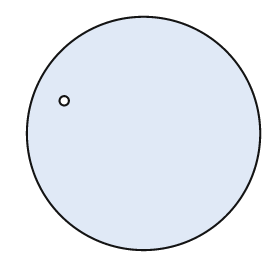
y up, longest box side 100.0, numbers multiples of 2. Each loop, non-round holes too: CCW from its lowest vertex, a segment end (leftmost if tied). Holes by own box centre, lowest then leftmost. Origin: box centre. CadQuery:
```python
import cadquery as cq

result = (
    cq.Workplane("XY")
    .moveTo(0.0, 0.0)
    .circle(50.0)
    .moveTo(-34.0, 14.0)
    .circle(2.0)
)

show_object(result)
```